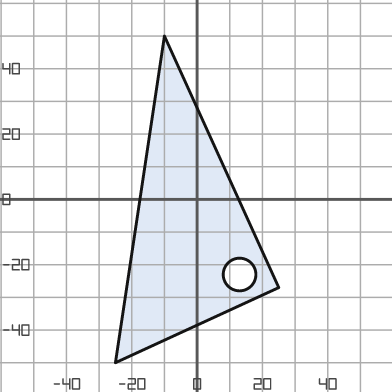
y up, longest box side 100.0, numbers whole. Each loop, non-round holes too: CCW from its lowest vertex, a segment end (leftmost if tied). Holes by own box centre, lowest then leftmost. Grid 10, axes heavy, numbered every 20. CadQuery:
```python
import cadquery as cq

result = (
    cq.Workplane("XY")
    .moveTo(-25.0, -50.0)
    .lineTo(25.0, -27.0)
    .lineTo(-10.0, 50.0)
    .close()
    .moveTo(13.0, -23.0)
    .circle(5.0)
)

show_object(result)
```